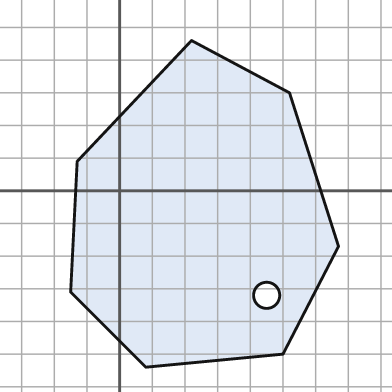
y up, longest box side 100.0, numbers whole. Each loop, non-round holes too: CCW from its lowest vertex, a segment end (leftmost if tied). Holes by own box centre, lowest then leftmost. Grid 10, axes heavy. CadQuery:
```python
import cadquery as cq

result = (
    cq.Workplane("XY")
    .moveTo(8.0, -54.0)
    .lineTo(50.0, -50.0)
    .lineTo(67.0, -17.0)
    .lineTo(52.0, 30.0)
    .lineTo(22.0, 46.0)
    .lineTo(-13.0, 9.0)
    .lineTo(-15.0, -31.0)
    .close()
    .moveTo(45.0, -32.0)
    .circle(4.0)
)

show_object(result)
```